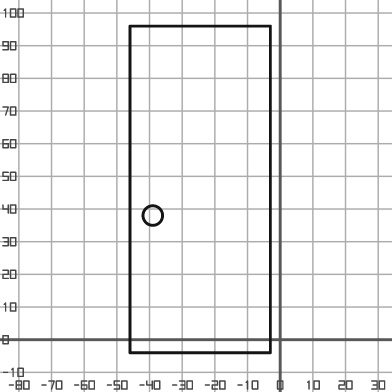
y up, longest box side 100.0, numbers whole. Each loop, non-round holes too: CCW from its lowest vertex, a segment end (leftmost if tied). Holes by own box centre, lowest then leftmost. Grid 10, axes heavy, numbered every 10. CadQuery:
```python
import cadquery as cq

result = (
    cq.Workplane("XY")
    .moveTo(-46.0, -4.0)
    .lineTo(-3.0, -4.0)
    .lineTo(-3.0, 96.0)
    .lineTo(-46.0, 96.0)
    .close()
    .moveTo(-39.0, 38.0)
    .circle(3.0)
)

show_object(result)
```